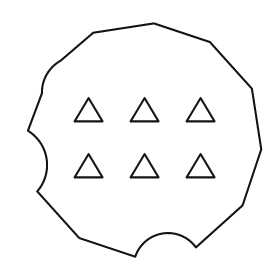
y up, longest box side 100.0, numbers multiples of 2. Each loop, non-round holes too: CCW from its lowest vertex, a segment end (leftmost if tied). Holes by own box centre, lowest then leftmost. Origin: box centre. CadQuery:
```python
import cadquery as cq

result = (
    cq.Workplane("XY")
    .moveTo(-4.0, -50.0)
    .threePointArc((8.0, -40.0), (22.0, -46.0))
    .lineTo(42.0, -28.0)
    .lineTo(50.0, -4.0)
    .lineTo(46.0, 22.0)
    .lineTo(28.0, 42.0)
    .lineTo(4.0, 50.0)
    .lineTo(-22.0, 46.0)
    .lineTo(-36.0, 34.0)
    .threePointArc((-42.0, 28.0), (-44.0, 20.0))
    .lineTo(-50.0, 4.0)
    .threePointArc((-42.0, -8.0), (-46.0, -22.0))
    .lineTo(-28.0, -42.0)
    .close()
    .moveTo(-30.0, -16.0)
    .lineTo(-18.0, -16.0)
    .lineTo(-24.0, -6.0)
    .close()
    .moveTo(-6.0, -16.0)
    .lineTo(6.0, -16.0)
    .lineTo(0.0, -6.0)
    .close()
    .moveTo(18.0, -16.0)
    .lineTo(30.0, -16.0)
    .lineTo(24.0, -6.0)
    .close()
    .moveTo(-30.0, 8.0)
    .lineTo(-18.0, 8.0)
    .lineTo(-24.0, 18.0)
    .close()
    .moveTo(-6.0, 8.0)
    .lineTo(6.0, 8.0)
    .lineTo(0.0, 18.0)
    .close()
    .moveTo(18.0, 8.0)
    .lineTo(30.0, 8.0)
    .lineTo(24.0, 18.0)
    .close()
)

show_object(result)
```